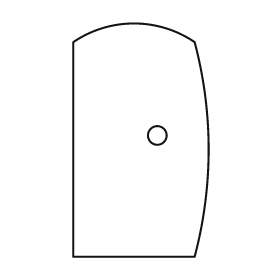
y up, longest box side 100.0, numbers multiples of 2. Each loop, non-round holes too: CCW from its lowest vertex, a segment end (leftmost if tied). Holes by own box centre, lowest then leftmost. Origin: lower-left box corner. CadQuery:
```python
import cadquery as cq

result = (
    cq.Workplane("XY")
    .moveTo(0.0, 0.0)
    .lineTo(52.0, 0.0)
    .threePointArc((58.0, 46.0), (52.0, 92.0))
    .threePointArc((26.0, 100.0), (0.0, 92.0))
    .close()
    .moveTo(36.0, 52.0)
    .circle(4.0)
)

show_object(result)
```